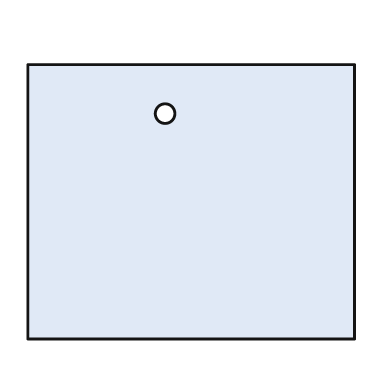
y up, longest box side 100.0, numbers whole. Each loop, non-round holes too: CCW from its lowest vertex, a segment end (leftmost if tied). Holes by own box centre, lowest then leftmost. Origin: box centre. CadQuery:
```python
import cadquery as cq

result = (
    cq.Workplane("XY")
    .moveTo(-50.0, -42.0)
    .lineTo(50.0, -42.0)
    .lineTo(50.0, 42.0)
    .lineTo(-50.0, 42.0)
    .close()
    .moveTo(-8.0, 27.0)
    .circle(3.0)
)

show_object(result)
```